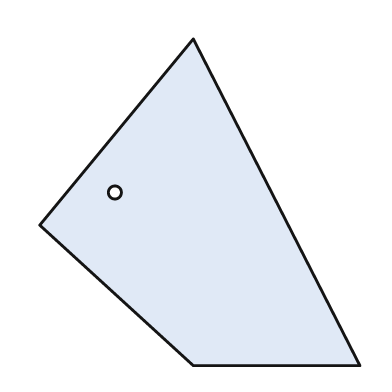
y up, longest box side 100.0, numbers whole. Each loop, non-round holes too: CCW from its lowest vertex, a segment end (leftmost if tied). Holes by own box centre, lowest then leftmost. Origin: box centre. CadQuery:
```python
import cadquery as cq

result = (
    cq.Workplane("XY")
    .moveTo(-2.0, -50.0)
    .lineTo(49.0, -50.0)
    .lineTo(-2.0, 50.0)
    .lineTo(-49.0, -7.0)
    .close()
    .moveTo(-26.0, 3.0)
    .circle(2.0)
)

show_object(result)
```